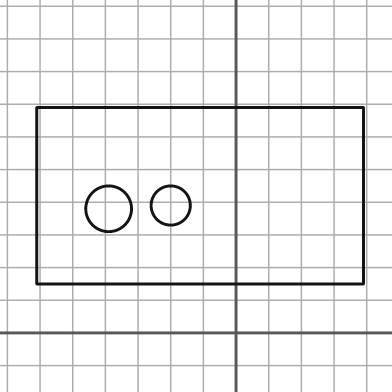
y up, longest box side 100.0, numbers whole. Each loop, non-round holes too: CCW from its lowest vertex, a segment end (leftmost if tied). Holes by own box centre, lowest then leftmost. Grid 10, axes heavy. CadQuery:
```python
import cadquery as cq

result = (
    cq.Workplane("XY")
    .moveTo(-61.0, 15.0)
    .lineTo(39.0, 15.0)
    .lineTo(39.0, 69.0)
    .lineTo(-61.0, 69.0)
    .close()
    .moveTo(-39.0, 38.0)
    .circle(7.0)
    .moveTo(-20.0, 39.0)
    .circle(6.0)
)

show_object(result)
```